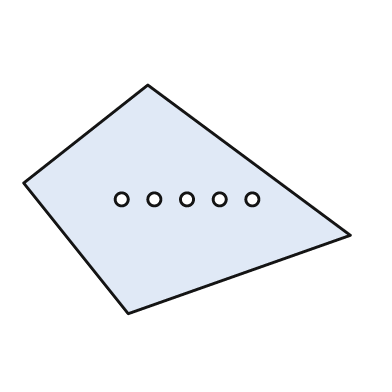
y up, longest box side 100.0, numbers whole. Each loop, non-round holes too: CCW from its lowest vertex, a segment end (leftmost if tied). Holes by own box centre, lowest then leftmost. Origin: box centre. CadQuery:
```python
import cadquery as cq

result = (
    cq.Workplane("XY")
    .moveTo(-18.0, -35.0)
    .lineTo(50.0, -11.0)
    .lineTo(-12.0, 35.0)
    .lineTo(-50.0, 5.0)
    .close()
    .moveTo(-20.0, 0.0)
    .circle(2.0)
    .moveTo(-10.0, 0.0)
    .circle(2.0)
    .moveTo(0.0, 0.0)
    .circle(2.0)
    .moveTo(10.0, 0.0)
    .circle(2.0)
    .moveTo(20.0, 0.0)
    .circle(2.0)
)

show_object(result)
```